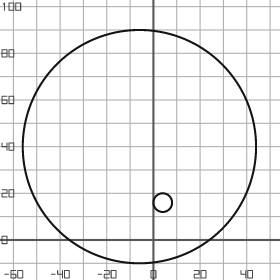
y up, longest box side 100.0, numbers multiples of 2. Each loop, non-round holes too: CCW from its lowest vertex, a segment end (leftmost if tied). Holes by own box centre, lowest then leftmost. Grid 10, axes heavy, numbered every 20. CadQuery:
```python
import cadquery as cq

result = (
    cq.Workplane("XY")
    .moveTo(-6.0, 40.0)
    .circle(50.0)
    .moveTo(4.0, 16.0)
    .circle(4.0)
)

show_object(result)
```